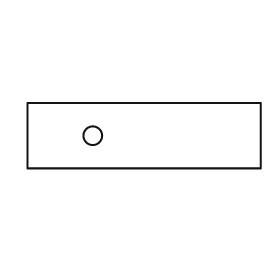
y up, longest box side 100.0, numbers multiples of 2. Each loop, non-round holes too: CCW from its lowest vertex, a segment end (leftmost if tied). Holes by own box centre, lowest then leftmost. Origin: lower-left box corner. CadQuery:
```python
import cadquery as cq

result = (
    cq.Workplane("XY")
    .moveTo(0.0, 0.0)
    .lineTo(100.0, 0.0)
    .lineTo(100.0, 28.0)
    .lineTo(0.0, 28.0)
    .close()
    .moveTo(28.0, 14.0)
    .circle(4.0)
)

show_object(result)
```